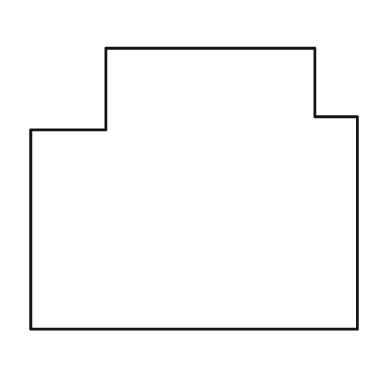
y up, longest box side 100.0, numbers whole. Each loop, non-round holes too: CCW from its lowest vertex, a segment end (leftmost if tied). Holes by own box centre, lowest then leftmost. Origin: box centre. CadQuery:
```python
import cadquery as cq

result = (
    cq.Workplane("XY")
    .moveTo(-50.0, -43.0)
    .lineTo(50.0, -43.0)
    .lineTo(50.0, 22.0)
    .lineTo(37.0, 22.0)
    .lineTo(37.0, 43.0)
    .lineTo(-27.0, 43.0)
    .lineTo(-27.0, 18.0)
    .lineTo(-50.0, 18.0)
    .close()
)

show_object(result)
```